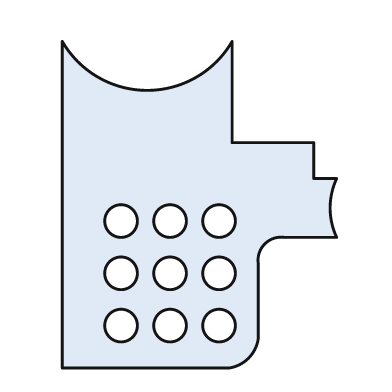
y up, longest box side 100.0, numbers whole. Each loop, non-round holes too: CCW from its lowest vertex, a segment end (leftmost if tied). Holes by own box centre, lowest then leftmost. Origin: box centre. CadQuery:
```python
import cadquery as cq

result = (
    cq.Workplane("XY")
    .moveTo(-42.0, -50.0)
    .lineTo(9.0, -50.0)
    .threePointArc((15.0, -47.0), (18.0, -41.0))
    .lineTo(18.0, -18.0)
    .threePointArc((20.0, -12.0), (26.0, -10.0))
    .lineTo(42.0, -10.0)
    .threePointArc((40.0, -1.0), (42.0, 8.0))
    .lineTo(35.0, 8.0)
    .lineTo(35.0, 19.0)
    .lineTo(10.0, 19.0)
    .lineTo(10.0, 50.0)
    .threePointArc((-16.0, 35.0), (-42.0, 50.0))
    .close()
    .moveTo(-24.0, -37.0)
    .circle(5.0)
    .moveTo(-9.0, -37.0)
    .circle(5.0)
    .moveTo(6.0, -37.0)
    .circle(5.0)
    .moveTo(-24.0, -21.0)
    .circle(5.0)
    .moveTo(-9.0, -21.0)
    .circle(5.0)
    .moveTo(6.0, -21.0)
    .circle(5.0)
    .moveTo(-24.0, -5.0)
    .circle(5.0)
    .moveTo(-9.0, -5.0)
    .circle(5.0)
    .moveTo(6.0, -5.0)
    .circle(5.0)
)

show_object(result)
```